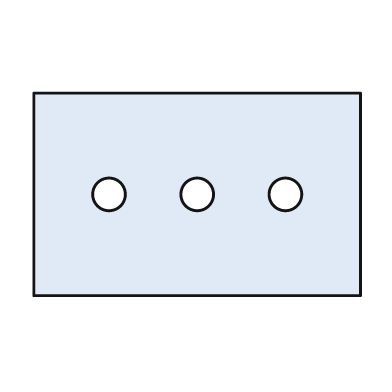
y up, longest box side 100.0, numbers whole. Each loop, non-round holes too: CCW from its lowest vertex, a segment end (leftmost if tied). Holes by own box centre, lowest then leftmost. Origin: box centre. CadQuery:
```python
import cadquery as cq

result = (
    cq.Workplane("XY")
    .moveTo(-50.0, -31.0)
    .lineTo(50.0, -31.0)
    .lineTo(50.0, 31.0)
    .lineTo(-50.0, 31.0)
    .close()
    .moveTo(-27.0, 0.0)
    .circle(5.0)
    .moveTo(0.0, 0.0)
    .circle(5.0)
    .moveTo(27.0, 0.0)
    .circle(5.0)
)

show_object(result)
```